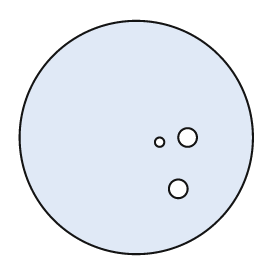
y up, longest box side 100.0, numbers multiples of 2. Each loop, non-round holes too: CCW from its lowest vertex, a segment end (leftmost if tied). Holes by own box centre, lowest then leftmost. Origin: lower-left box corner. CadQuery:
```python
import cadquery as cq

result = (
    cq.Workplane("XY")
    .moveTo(50.0, 50.0)
    .circle(50.0)
    .moveTo(68.0, 28.0)
    .circle(4.0)
    .moveTo(60.0, 48.0)
    .circle(2.0)
    .moveTo(72.0, 50.0)
    .circle(4.0)
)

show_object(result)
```